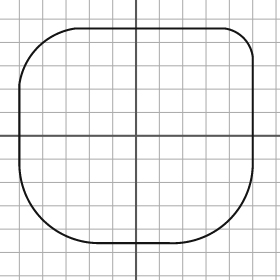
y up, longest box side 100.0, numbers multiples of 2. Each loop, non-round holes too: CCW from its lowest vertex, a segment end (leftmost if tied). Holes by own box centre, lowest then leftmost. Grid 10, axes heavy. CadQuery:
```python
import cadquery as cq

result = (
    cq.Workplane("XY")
    .moveTo(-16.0, -46.0)
    .lineTo(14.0, -46.0)
    .threePointArc((40.0, -36.0), (50.0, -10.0))
    .lineTo(50.0, 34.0)
    .threePointArc((46.0, 42.0), (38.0, 46.0))
    .lineTo(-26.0, 46.0)
    .threePointArc((-42.0, 38.0), (-50.0, 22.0))
    .lineTo(-50.0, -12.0)
    .threePointArc((-40.0, -36.0), (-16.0, -46.0))
    .close()
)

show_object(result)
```